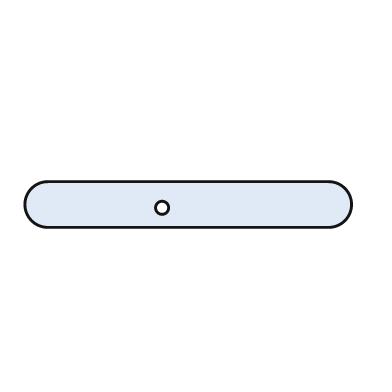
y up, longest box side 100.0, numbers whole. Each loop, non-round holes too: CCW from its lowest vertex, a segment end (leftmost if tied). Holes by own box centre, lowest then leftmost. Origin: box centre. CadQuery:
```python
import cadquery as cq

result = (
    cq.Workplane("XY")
    .moveTo(-43.0, -7.0)
    .lineTo(43.0, -7.0)
    .threePointArc((50.0, 0.0), (43.0, 7.0))
    .lineTo(-43.0, 7.0)
    .threePointArc((-50.0, 0.0), (-43.0, -7.0))
    .close()
    .moveTo(-8.0, -1.0)
    .circle(2.0)
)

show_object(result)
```